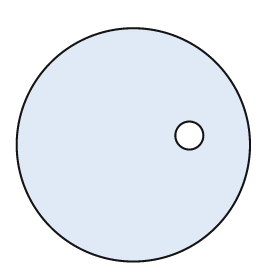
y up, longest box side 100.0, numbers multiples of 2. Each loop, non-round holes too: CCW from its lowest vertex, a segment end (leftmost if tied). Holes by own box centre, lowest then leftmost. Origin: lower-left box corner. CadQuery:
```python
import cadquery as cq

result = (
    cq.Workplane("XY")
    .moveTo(50.0, 50.0)
    .circle(50.0)
    .moveTo(74.0, 54.0)
    .circle(6.0)
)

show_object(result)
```